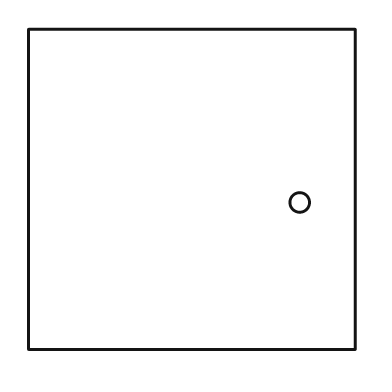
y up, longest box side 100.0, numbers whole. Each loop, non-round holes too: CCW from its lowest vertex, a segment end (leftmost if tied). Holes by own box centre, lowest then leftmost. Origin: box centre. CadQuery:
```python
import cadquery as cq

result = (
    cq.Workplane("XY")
    .moveTo(-50.0, -49.0)
    .lineTo(50.0, -49.0)
    .lineTo(50.0, 49.0)
    .lineTo(-50.0, 49.0)
    .close()
    .moveTo(33.0, -4.0)
    .circle(3.0)
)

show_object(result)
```